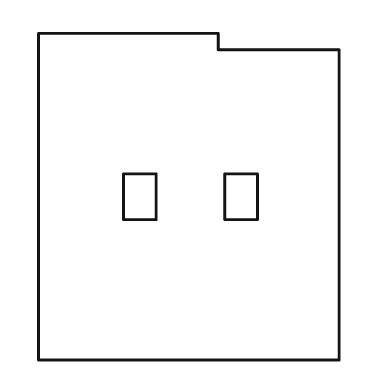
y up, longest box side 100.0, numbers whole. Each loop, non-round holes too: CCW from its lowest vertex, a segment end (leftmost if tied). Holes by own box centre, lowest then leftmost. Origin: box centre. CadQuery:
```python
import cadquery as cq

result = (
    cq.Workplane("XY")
    .moveTo(-46.0, -50.0)
    .lineTo(46.0, -50.0)
    .lineTo(46.0, 45.0)
    .lineTo(9.0, 45.0)
    .lineTo(9.0, 50.0)
    .lineTo(-46.0, 50.0)
    .close()
    .moveTo(-20.0, -7.0)
    .lineTo(-10.0, -7.0)
    .lineTo(-10.0, 7.0)
    .lineTo(-20.0, 7.0)
    .close()
    .moveTo(11.0, -7.0)
    .lineTo(21.0, -7.0)
    .lineTo(21.0, 7.0)
    .lineTo(11.0, 7.0)
    .close()
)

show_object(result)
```